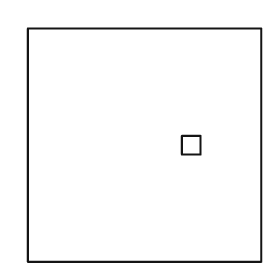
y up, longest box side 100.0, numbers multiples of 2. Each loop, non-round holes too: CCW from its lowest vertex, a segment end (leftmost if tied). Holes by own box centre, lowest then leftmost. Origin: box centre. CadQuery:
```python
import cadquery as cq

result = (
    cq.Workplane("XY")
    .moveTo(-50.0, -50.0)
    .lineTo(50.0, -50.0)
    .lineTo(50.0, 50.0)
    .lineTo(-50.0, 50.0)
    .close()
    .moveTo(16.0, -4.0)
    .lineTo(24.0, -4.0)
    .lineTo(24.0, 4.0)
    .lineTo(16.0, 4.0)
    .close()
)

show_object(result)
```